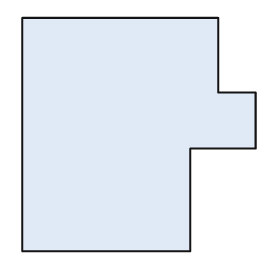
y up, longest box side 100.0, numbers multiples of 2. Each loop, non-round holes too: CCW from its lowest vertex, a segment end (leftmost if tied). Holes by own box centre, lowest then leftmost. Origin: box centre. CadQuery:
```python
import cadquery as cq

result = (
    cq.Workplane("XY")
    .moveTo(-50.0, -50.0)
    .lineTo(22.0, -50.0)
    .lineTo(22.0, -6.0)
    .lineTo(50.0, -6.0)
    .lineTo(50.0, 18.0)
    .lineTo(34.0, 18.0)
    .lineTo(34.0, 50.0)
    .lineTo(-50.0, 50.0)
    .close()
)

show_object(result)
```